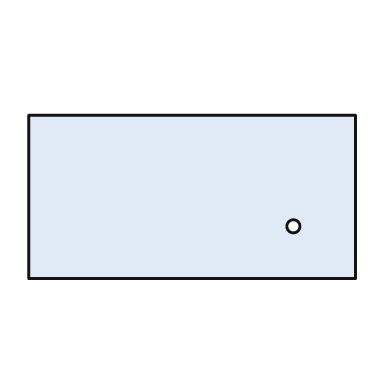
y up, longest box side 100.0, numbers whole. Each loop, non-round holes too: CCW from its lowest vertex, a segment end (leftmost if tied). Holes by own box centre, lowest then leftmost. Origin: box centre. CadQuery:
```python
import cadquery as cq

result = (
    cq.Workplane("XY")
    .moveTo(-50.0, -25.0)
    .lineTo(50.0, -25.0)
    .lineTo(50.0, 25.0)
    .lineTo(-50.0, 25.0)
    .close()
    .moveTo(31.0, -9.0)
    .circle(2.0)
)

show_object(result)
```